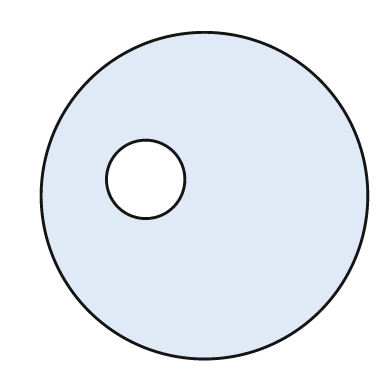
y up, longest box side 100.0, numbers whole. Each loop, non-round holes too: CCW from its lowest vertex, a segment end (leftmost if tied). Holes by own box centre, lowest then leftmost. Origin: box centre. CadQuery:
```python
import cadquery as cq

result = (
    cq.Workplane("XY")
    .moveTo(0.0, 0.0)
    .circle(50.0)
    .moveTo(-18.0, 5.0)
    .circle(12.0)
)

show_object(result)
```